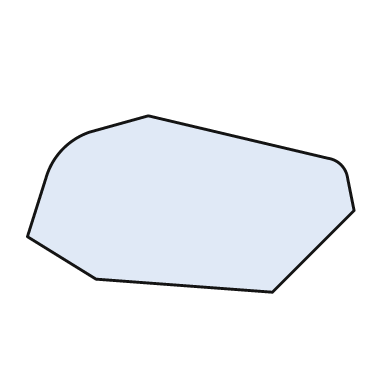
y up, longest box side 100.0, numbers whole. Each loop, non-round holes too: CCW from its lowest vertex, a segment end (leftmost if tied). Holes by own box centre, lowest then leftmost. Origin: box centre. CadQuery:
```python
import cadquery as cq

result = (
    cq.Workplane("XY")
    .moveTo(25.0, -27.0)
    .lineTo(50.0, -2.0)
    .lineTo(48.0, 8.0)
    .threePointArc((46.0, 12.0), (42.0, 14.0))
    .lineTo(-13.0, 27.0)
    .lineTo(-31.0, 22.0)
    .threePointArc((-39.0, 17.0), (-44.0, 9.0))
    .lineTo(-50.0, -10.0)
    .lineTo(-29.0, -23.0)
    .close()
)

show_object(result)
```